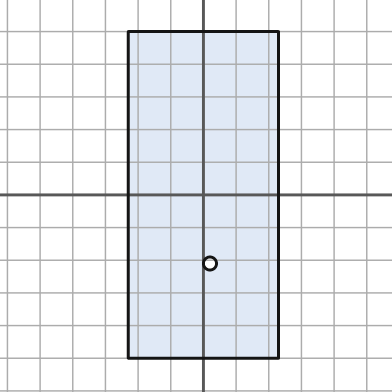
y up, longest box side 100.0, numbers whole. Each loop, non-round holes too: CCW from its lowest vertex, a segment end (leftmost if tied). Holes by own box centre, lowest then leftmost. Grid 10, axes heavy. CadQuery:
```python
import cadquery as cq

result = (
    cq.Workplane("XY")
    .moveTo(-23.0, -50.0)
    .lineTo(23.0, -50.0)
    .lineTo(23.0, 50.0)
    .lineTo(-23.0, 50.0)
    .close()
    .moveTo(2.0, -21.0)
    .circle(2.0)
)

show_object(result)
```